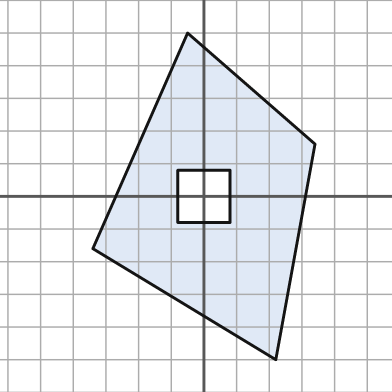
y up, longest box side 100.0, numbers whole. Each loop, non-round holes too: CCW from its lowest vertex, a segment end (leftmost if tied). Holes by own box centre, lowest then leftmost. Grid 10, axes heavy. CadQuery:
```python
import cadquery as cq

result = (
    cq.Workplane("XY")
    .moveTo(22.0, -50.0)
    .lineTo(34.0, 16.0)
    .lineTo(-5.0, 50.0)
    .lineTo(-34.0, -16.0)
    .close()
    .moveTo(-8.0, -8.0)
    .lineTo(8.0, -8.0)
    .lineTo(8.0, 8.0)
    .lineTo(-8.0, 8.0)
    .close()
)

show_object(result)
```